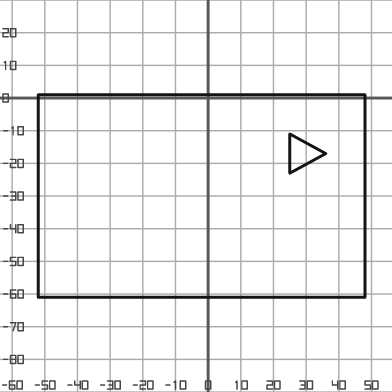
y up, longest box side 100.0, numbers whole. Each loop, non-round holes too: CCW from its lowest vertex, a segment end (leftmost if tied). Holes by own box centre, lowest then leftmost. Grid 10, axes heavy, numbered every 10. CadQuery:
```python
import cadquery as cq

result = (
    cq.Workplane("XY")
    .moveTo(-52.0, -61.0)
    .lineTo(48.0, -61.0)
    .lineTo(48.0, 1.0)
    .lineTo(-52.0, 1.0)
    .close()
    .moveTo(25.0, -23.0)
    .lineTo(36.0, -17.0)
    .lineTo(25.0, -11.0)
    .close()
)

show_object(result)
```